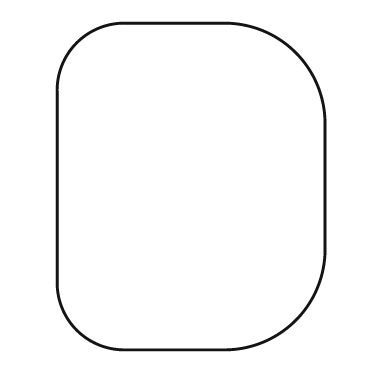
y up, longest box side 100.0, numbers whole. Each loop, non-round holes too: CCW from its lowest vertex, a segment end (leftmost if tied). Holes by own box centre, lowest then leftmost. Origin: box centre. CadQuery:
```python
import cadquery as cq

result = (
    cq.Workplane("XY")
    .moveTo(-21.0, -50.0)
    .lineTo(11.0, -50.0)
    .threePointArc((32.0, -41.0), (41.0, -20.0))
    .lineTo(41.0, 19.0)
    .threePointArc((32.0, 41.0), (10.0, 50.0))
    .lineTo(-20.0, 50.0)
    .threePointArc((-35.0, 44.0), (-41.0, 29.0))
    .lineTo(-41.0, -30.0)
    .threePointArc((-35.0, -44.0), (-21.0, -50.0))
    .close()
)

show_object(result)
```